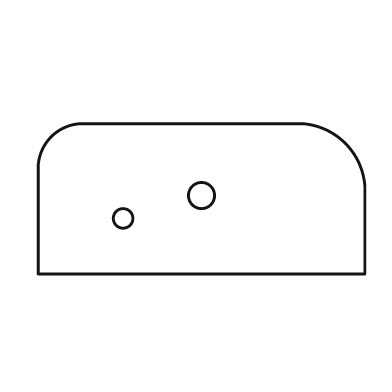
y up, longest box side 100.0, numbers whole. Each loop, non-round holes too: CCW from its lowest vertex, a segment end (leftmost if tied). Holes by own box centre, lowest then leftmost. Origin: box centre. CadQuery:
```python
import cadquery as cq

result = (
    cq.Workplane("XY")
    .moveTo(-50.0, -23.0)
    .lineTo(50.0, -23.0)
    .lineTo(50.0, 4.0)
    .threePointArc((44.0, 17.0), (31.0, 23.0))
    .lineTo(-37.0, 23.0)
    .threePointArc((-46.0, 19.0), (-50.0, 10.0))
    .close()
    .moveTo(-24.0, -6.0)
    .circle(3.0)
    .moveTo(0.0, 1.0)
    .circle(4.0)
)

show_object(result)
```